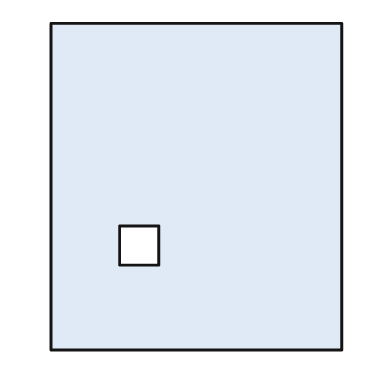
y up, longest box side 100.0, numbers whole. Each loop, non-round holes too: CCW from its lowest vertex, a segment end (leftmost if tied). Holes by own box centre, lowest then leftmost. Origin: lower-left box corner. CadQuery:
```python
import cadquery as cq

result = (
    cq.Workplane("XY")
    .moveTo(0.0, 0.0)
    .lineTo(89.0, 0.0)
    .lineTo(89.0, 100.0)
    .lineTo(0.0, 100.0)
    .close()
    .moveTo(21.0, 26.0)
    .lineTo(33.0, 26.0)
    .lineTo(33.0, 38.0)
    .lineTo(21.0, 38.0)
    .close()
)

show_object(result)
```